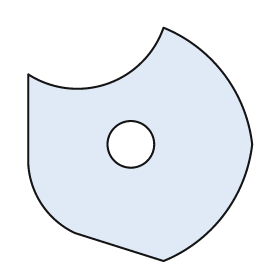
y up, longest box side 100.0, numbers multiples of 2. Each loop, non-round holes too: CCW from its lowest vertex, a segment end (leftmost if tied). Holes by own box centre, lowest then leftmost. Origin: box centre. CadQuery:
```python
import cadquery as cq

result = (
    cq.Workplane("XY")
    .moveTo(10.0, -50.0)
    .threePointArc((36.0, -30.0), (48.0, 0.0))
    .threePointArc((36.0, 30.0), (10.0, 50.0))
    .threePointArc((-14.0, 26.0), (-48.0, 30.0))
    .lineTo(-48.0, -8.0)
    .threePointArc((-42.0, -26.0), (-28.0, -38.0))
    .close()
    .moveTo(-4.0, 0.0)
    .circle(10.0)
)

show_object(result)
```